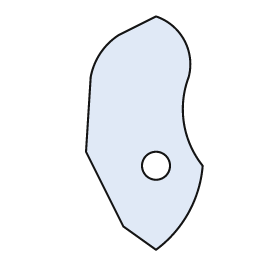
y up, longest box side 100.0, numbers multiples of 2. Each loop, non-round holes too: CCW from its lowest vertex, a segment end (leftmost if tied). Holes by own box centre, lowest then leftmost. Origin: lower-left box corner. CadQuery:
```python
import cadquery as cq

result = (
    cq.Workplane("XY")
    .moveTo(30.0, 0.0)
    .threePointArc((44.0, 16.0), (50.0, 36.0))
    .threePointArc((42.0, 54.0), (44.0, 74.0))
    .threePointArc((42.0, 90.0), (30.0, 100.0))
    .lineTo(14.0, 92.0)
    .threePointArc((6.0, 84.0), (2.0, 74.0))
    .lineTo(0.0, 42.0)
    .lineTo(16.0, 10.0)
    .close()
    .moveTo(30.0, 36.0)
    .circle(6.0)
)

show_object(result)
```